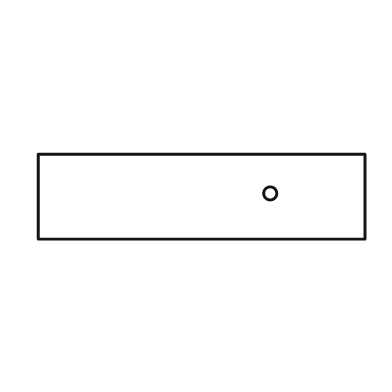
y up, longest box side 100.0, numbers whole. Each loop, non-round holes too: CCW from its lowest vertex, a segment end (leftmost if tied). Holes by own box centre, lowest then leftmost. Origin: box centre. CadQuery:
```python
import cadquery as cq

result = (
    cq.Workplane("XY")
    .moveTo(-50.0, -13.0)
    .lineTo(50.0, -13.0)
    .lineTo(50.0, 13.0)
    .lineTo(-50.0, 13.0)
    .close()
    .moveTo(21.0, 1.0)
    .circle(2.0)
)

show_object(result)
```